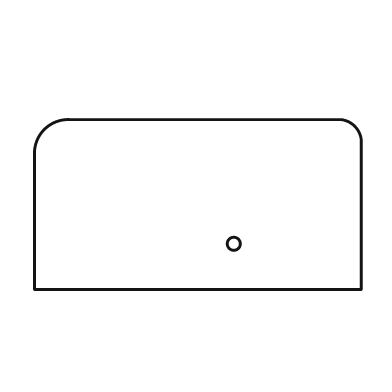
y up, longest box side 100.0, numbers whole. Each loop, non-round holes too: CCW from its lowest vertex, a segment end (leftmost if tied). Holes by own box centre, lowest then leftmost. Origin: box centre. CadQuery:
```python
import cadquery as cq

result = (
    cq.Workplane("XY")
    .moveTo(-50.0, -26.0)
    .lineTo(50.0, -26.0)
    .lineTo(50.0, 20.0)
    .threePointArc((48.0, 24.0), (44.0, 26.0))
    .lineTo(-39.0, 26.0)
    .threePointArc((-47.0, 23.0), (-50.0, 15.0))
    .close()
    .moveTo(11.0, -12.0)
    .circle(2.0)
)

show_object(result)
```